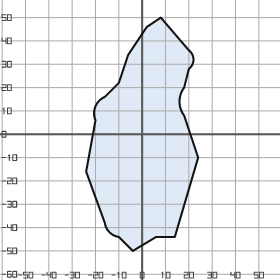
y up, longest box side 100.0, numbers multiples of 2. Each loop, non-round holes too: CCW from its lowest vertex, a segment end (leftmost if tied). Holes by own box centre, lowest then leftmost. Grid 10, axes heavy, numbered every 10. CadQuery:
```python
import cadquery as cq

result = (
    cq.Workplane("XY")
    .moveTo(-4.0, -50.0)
    .lineTo(6.0, -44.0)
    .lineTo(14.0, -44.0)
    .lineTo(24.0, -10.0)
    .lineTo(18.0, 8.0)
    .threePointArc((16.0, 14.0), (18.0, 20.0))
    .lineTo(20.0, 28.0)
    .threePointArc((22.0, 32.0), (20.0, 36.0))
    .lineTo(8.0, 50.0)
    .lineTo(2.0, 46.0)
    .lineTo(-6.0, 34.0)
    .lineTo(-10.0, 22.0)
    .lineTo(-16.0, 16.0)
    .threePointArc((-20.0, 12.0), (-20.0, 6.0))
    .lineTo(-24.0, -16.0)
    .lineTo(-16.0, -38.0)
    .threePointArc((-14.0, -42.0), (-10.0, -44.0))
    .close()
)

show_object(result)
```